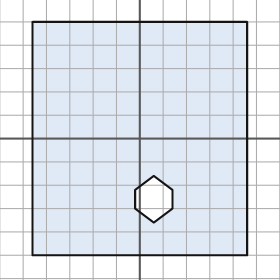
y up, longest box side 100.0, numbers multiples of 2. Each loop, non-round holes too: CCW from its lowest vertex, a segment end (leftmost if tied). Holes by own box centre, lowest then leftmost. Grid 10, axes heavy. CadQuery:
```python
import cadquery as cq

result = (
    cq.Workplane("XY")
    .moveTo(-46.0, -50.0)
    .lineTo(46.0, -50.0)
    .lineTo(46.0, 50.0)
    .lineTo(-46.0, 50.0)
    .close()
    .moveTo(6.0, -36.0)
    .lineTo(14.0, -30.0)
    .lineTo(14.0, -22.0)
    .lineTo(6.0, -16.0)
    .lineTo(-2.0, -22.0)
    .lineTo(-2.0, -30.0)
    .close()
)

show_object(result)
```